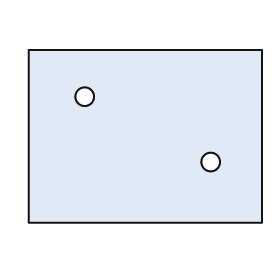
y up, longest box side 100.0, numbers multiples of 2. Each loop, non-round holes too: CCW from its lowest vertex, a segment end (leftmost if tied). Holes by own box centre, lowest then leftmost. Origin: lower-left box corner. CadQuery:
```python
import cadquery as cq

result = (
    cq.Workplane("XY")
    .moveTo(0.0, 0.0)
    .lineTo(100.0, 0.0)
    .lineTo(100.0, 74.0)
    .lineTo(0.0, 74.0)
    .close()
    .moveTo(78.0, 26.0)
    .circle(4.0)
    .moveTo(24.0, 54.0)
    .circle(4.0)
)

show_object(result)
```